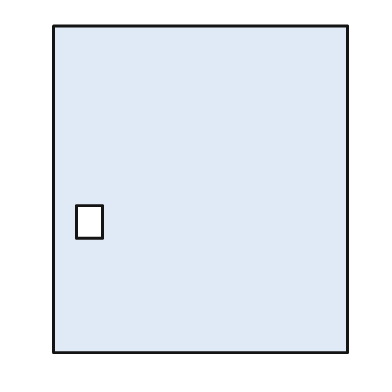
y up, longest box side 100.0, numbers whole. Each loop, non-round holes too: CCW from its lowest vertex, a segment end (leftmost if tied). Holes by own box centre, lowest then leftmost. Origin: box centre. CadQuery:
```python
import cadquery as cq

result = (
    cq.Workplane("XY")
    .moveTo(-45.0, -50.0)
    .lineTo(45.0, -50.0)
    .lineTo(45.0, 50.0)
    .lineTo(-45.0, 50.0)
    .close()
    .moveTo(-38.0, -15.0)
    .lineTo(-30.0, -15.0)
    .lineTo(-30.0, -5.0)
    .lineTo(-38.0, -5.0)
    .close()
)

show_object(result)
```